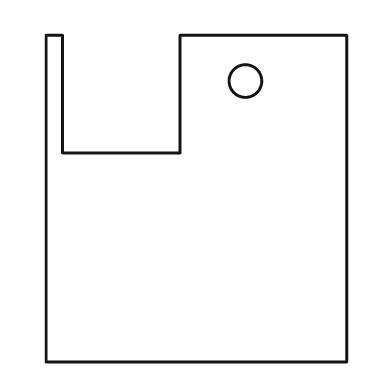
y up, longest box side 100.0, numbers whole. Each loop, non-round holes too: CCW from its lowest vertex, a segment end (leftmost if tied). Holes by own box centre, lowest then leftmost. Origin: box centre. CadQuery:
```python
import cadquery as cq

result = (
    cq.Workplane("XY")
    .moveTo(-46.0, -50.0)
    .lineTo(46.0, -50.0)
    .lineTo(46.0, 50.0)
    .lineTo(-5.0, 50.0)
    .lineTo(-5.0, 14.0)
    .lineTo(-41.0, 14.0)
    .lineTo(-41.0, 50.0)
    .lineTo(-46.0, 50.0)
    .close()
    .moveTo(15.0, 36.0)
    .circle(5.0)
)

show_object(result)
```